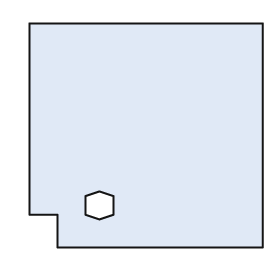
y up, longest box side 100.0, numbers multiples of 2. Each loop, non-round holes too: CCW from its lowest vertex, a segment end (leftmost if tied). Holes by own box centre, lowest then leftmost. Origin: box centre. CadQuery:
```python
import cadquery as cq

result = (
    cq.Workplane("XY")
    .moveTo(-38.0, -48.0)
    .lineTo(50.0, -48.0)
    .lineTo(50.0, 48.0)
    .lineTo(-50.0, 48.0)
    .lineTo(-50.0, -34.0)
    .lineTo(-38.0, -34.0)
    .close()
    .moveTo(-20.0, -36.0)
    .lineTo(-14.0, -34.0)
    .lineTo(-14.0, -26.0)
    .lineTo(-20.0, -24.0)
    .lineTo(-26.0, -26.0)
    .lineTo(-26.0, -34.0)
    .close()
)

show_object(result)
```